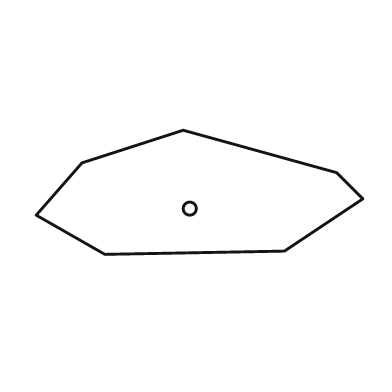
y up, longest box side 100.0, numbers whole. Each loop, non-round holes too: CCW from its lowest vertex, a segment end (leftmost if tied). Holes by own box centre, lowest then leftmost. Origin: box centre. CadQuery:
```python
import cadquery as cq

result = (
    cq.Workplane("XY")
    .moveTo(-29.0, -19.0)
    .lineTo(26.0, -18.0)
    .lineTo(50.0, -2.0)
    .lineTo(42.0, 6.0)
    .lineTo(-5.0, 19.0)
    .lineTo(-36.0, 9.0)
    .lineTo(-50.0, -7.0)
    .close()
    .moveTo(-3.0, -5.0)
    .circle(2.0)
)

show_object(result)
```